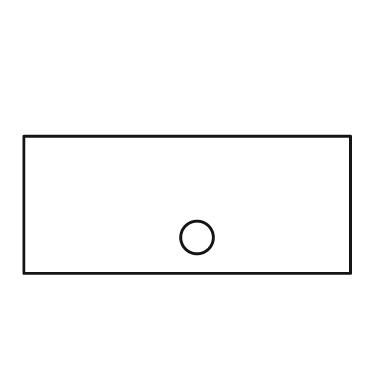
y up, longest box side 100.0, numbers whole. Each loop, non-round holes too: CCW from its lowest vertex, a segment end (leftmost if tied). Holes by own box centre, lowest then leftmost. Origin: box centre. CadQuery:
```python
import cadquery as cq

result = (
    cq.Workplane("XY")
    .moveTo(-50.0, -21.0)
    .lineTo(50.0, -21.0)
    .lineTo(50.0, 21.0)
    .lineTo(-50.0, 21.0)
    .close()
    .moveTo(3.0, -10.0)
    .circle(5.0)
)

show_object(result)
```